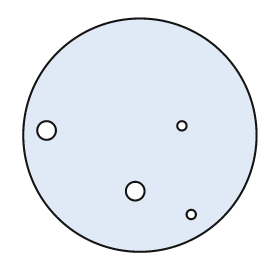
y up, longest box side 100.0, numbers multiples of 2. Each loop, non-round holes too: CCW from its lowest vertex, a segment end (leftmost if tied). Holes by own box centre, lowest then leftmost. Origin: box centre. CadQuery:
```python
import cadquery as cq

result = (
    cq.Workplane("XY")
    .moveTo(0.0, 0.0)
    .circle(50.0)
    .moveTo(22.0, -34.0)
    .circle(2.0)
    .moveTo(-2.0, -24.0)
    .circle(4.0)
    .moveTo(-40.0, 2.0)
    .circle(4.0)
    .moveTo(18.0, 4.0)
    .circle(2.0)
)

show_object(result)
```